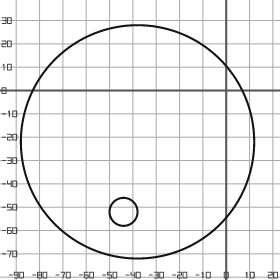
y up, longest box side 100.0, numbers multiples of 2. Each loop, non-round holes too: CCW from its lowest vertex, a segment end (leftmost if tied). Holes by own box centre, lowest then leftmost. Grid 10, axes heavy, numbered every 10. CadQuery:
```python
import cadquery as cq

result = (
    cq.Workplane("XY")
    .moveTo(-38.0, -22.0)
    .circle(50.0)
    .moveTo(-44.0, -52.0)
    .circle(6.0)
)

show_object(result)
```